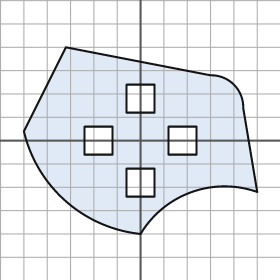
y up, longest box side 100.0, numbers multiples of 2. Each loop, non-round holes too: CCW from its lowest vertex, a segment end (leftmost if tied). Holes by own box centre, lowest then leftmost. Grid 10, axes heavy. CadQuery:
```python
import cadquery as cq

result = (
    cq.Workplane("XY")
    .moveTo(0.0, -40.0)
    .threePointArc((22.0, -22.0), (50.0, -22.0))
    .lineTo(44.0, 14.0)
    .threePointArc((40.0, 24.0), (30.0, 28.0))
    .lineTo(-32.0, 40.0)
    .lineTo(-50.0, 4.0)
    .threePointArc((-32.0, -26.0), (0.0, -40.0))
    .close()
    .moveTo(-6.0, -24.0)
    .lineTo(6.0, -24.0)
    .lineTo(6.0, -12.0)
    .lineTo(-6.0, -12.0)
    .close()
    .moveTo(-24.0, -6.0)
    .lineTo(-12.0, -6.0)
    .lineTo(-12.0, 6.0)
    .lineTo(-24.0, 6.0)
    .close()
    .moveTo(12.0, -6.0)
    .lineTo(24.0, -6.0)
    .lineTo(24.0, 6.0)
    .lineTo(12.0, 6.0)
    .close()
    .moveTo(-6.0, 12.0)
    .lineTo(6.0, 12.0)
    .lineTo(6.0, 24.0)
    .lineTo(-6.0, 24.0)
    .close()
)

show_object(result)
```